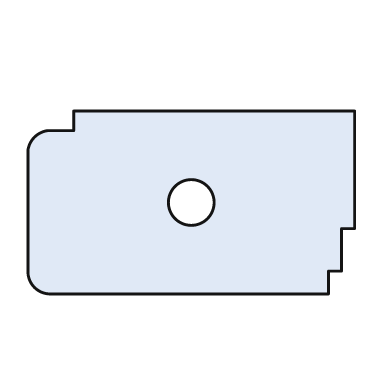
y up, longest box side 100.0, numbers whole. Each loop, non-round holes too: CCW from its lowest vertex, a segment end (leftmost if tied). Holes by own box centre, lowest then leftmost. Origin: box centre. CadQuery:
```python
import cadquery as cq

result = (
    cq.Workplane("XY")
    .moveTo(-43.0, -28.0)
    .lineTo(42.0, -28.0)
    .lineTo(42.0, -21.0)
    .lineTo(46.0, -21.0)
    .lineTo(46.0, -8.0)
    .lineTo(50.0, -8.0)
    .lineTo(50.0, 28.0)
    .lineTo(-36.0, 28.0)
    .lineTo(-36.0, 22.0)
    .lineTo(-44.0, 22.0)
    .threePointArc((-48.0, 20.0), (-50.0, 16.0))
    .lineTo(-50.0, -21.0)
    .threePointArc((-48.0, -26.0), (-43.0, -28.0))
    .close()
    .moveTo(0.0, 0.0)
    .circle(7.0)
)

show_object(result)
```